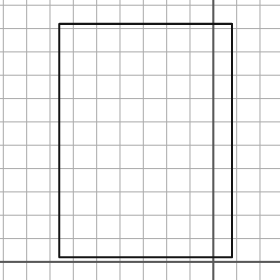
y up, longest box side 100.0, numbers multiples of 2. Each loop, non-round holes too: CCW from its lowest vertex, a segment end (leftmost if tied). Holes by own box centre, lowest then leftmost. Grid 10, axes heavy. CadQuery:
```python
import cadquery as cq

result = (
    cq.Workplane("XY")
    .moveTo(-66.0, 2.0)
    .lineTo(8.0, 2.0)
    .lineTo(8.0, 102.0)
    .lineTo(-66.0, 102.0)
    .close()
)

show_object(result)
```